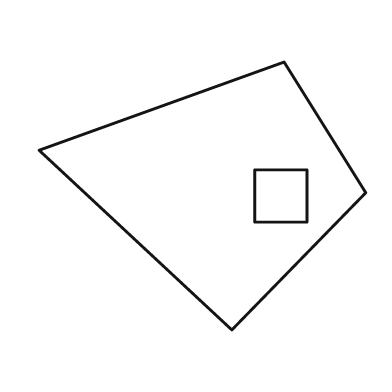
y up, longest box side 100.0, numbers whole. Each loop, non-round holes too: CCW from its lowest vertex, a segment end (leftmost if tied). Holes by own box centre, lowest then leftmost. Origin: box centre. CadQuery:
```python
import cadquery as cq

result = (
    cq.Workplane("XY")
    .moveTo(9.0, -41.0)
    .lineTo(50.0, 1.0)
    .lineTo(25.0, 41.0)
    .lineTo(-50.0, 14.0)
    .close()
    .moveTo(16.0, -8.0)
    .lineTo(32.0, -8.0)
    .lineTo(32.0, 8.0)
    .lineTo(16.0, 8.0)
    .close()
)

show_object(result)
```